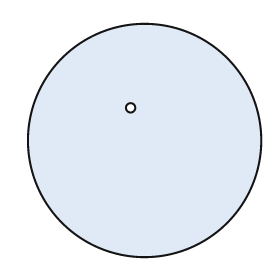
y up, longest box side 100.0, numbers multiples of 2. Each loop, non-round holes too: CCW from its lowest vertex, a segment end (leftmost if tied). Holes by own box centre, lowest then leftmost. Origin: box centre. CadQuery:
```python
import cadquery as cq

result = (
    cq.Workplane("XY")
    .moveTo(0.0, 0.0)
    .circle(50.0)
    .moveTo(-6.0, 14.0)
    .circle(2.0)
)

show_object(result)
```